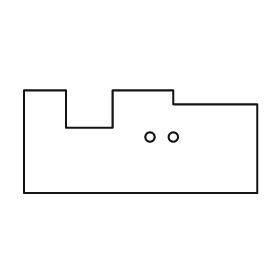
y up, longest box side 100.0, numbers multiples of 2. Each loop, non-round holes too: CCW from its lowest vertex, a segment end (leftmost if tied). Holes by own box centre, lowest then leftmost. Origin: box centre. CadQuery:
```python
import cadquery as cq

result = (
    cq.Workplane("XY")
    .moveTo(-50.0, -22.0)
    .lineTo(50.0, -22.0)
    .lineTo(50.0, 16.0)
    .lineTo(14.0, 16.0)
    .lineTo(14.0, 22.0)
    .lineTo(-12.0, 22.0)
    .lineTo(-12.0, 6.0)
    .lineTo(-32.0, 6.0)
    .lineTo(-32.0, 22.0)
    .lineTo(-50.0, 22.0)
    .close()
    .moveTo(4.0, 2.0)
    .circle(2.0)
    .moveTo(14.0, 2.0)
    .circle(2.0)
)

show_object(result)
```